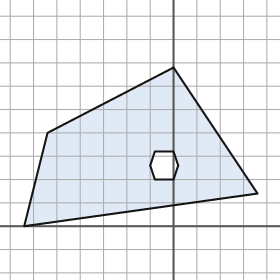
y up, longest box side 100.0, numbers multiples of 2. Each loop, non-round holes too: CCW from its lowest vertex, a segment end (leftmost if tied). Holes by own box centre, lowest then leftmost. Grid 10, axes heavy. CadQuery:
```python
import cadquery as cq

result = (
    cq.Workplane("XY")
    .moveTo(-64.0, 0.0)
    .lineTo(36.0, 14.0)
    .lineTo(0.0, 68.0)
    .lineTo(-54.0, 40.0)
    .close()
    .moveTo(-8.0, 20.0)
    .lineTo(0.0, 20.0)
    .lineTo(2.0, 26.0)
    .lineTo(0.0, 32.0)
    .lineTo(-8.0, 32.0)
    .lineTo(-10.0, 26.0)
    .close()
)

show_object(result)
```